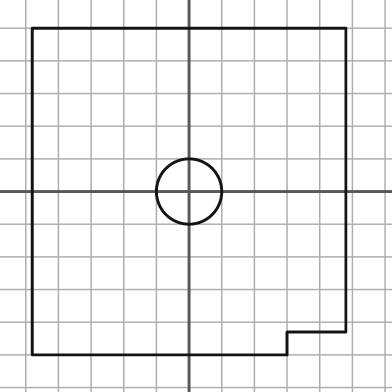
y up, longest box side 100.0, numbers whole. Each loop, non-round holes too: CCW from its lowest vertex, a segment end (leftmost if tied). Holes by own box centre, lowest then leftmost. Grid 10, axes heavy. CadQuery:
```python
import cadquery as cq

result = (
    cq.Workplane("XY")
    .moveTo(-48.0, -50.0)
    .lineTo(30.0, -50.0)
    .lineTo(30.0, -43.0)
    .lineTo(48.0, -43.0)
    .lineTo(48.0, 50.0)
    .lineTo(-48.0, 50.0)
    .close()
    .moveTo(0.0, 0.0)
    .circle(10.0)
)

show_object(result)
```